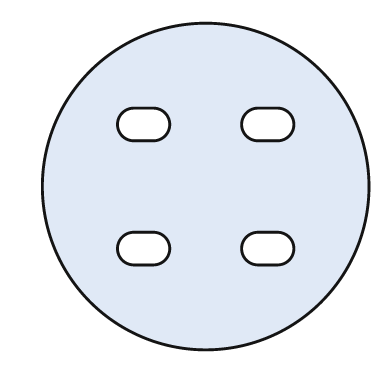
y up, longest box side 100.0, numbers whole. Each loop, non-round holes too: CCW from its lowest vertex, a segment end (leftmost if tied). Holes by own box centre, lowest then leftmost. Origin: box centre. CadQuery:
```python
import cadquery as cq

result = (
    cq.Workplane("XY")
    .moveTo(0.0, 0.0)
    .circle(50.0)
    .moveTo(-22.0, -24.0)
    .lineTo(-16.0, -24.0)
    .threePointArc((-11.0, -19.0), (-16.0, -14.0))
    .lineTo(-22.0, -14.0)
    .threePointArc((-27.0, -19.0), (-22.0, -24.0))
    .close()
    .moveTo(16.0, -24.0)
    .lineTo(22.0, -24.0)
    .threePointArc((27.0, -19.0), (22.0, -14.0))
    .lineTo(16.0, -14.0)
    .threePointArc((11.0, -19.0), (16.0, -24.0))
    .close()
    .moveTo(-22.0, 14.0)
    .lineTo(-16.0, 14.0)
    .threePointArc((-11.0, 19.0), (-16.0, 24.0))
    .lineTo(-22.0, 24.0)
    .threePointArc((-27.0, 19.0), (-22.0, 14.0))
    .close()
    .moveTo(16.0, 14.0)
    .lineTo(22.0, 14.0)
    .threePointArc((27.0, 19.0), (22.0, 24.0))
    .lineTo(16.0, 24.0)
    .threePointArc((11.0, 19.0), (16.0, 14.0))
    .close()
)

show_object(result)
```